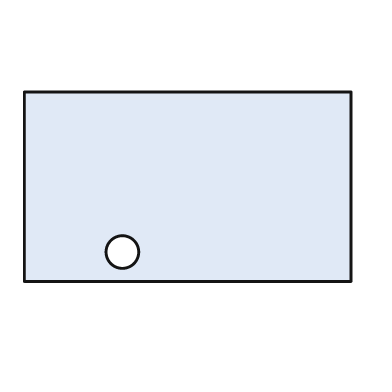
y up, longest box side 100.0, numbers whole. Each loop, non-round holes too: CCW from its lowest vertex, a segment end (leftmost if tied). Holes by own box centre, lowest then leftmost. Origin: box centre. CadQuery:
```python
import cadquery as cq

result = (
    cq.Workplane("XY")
    .moveTo(-50.0, -29.0)
    .lineTo(50.0, -29.0)
    .lineTo(50.0, 29.0)
    .lineTo(-50.0, 29.0)
    .close()
    .moveTo(-20.0, -20.0)
    .circle(5.0)
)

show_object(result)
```